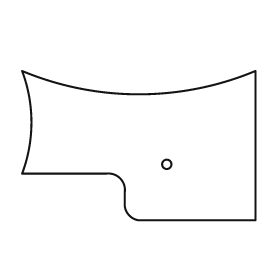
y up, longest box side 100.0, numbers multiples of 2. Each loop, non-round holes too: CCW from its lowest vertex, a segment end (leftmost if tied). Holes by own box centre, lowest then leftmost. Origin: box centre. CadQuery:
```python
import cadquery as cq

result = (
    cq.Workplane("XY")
    .moveTo(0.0, -32.0)
    .lineTo(50.0, -32.0)
    .lineTo(50.0, 32.0)
    .threePointArc((0.0, 22.0), (-50.0, 32.0))
    .threePointArc((-46.0, 10.0), (-50.0, -12.0))
    .lineTo(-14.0, -12.0)
    .threePointArc((-8.0, -14.0), (-6.0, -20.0))
    .lineTo(-6.0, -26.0)
    .threePointArc((-4.0, -30.0), (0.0, -32.0))
    .close()
    .moveTo(12.0, -8.0)
    .circle(2.0)
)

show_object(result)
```